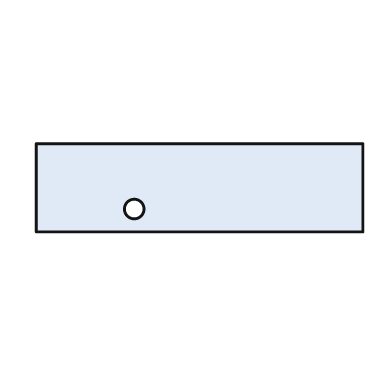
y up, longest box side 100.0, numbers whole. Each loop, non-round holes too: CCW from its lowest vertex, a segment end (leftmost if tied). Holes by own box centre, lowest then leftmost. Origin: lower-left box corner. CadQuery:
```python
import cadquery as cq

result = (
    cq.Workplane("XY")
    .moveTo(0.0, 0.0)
    .lineTo(100.0, 0.0)
    .lineTo(100.0, 27.0)
    .lineTo(0.0, 27.0)
    .close()
    .moveTo(30.0, 7.0)
    .circle(3.0)
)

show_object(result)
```